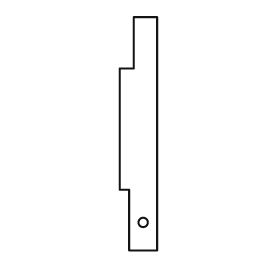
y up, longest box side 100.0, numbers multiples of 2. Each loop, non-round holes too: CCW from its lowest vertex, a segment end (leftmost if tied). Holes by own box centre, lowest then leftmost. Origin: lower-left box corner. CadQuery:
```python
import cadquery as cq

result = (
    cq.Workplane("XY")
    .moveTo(4.0, 0.0)
    .lineTo(16.0, 0.0)
    .lineTo(16.0, 100.0)
    .lineTo(6.0, 100.0)
    .lineTo(6.0, 78.0)
    .lineTo(0.0, 78.0)
    .lineTo(0.0, 26.0)
    .lineTo(4.0, 26.0)
    .close()
    .moveTo(10.0, 12.0)
    .circle(2.0)
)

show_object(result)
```